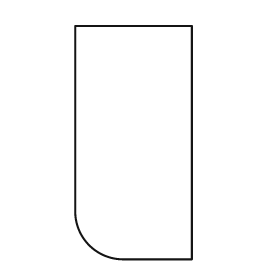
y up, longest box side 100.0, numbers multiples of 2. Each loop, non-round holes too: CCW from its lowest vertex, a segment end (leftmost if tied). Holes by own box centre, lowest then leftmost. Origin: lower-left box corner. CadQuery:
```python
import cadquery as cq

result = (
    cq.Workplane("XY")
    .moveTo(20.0, 0.0)
    .lineTo(50.0, 0.0)
    .lineTo(50.0, 100.0)
    .lineTo(0.0, 100.0)
    .lineTo(0.0, 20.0)
    .threePointArc((6.0, 6.0), (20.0, 0.0))
    .close()
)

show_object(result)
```